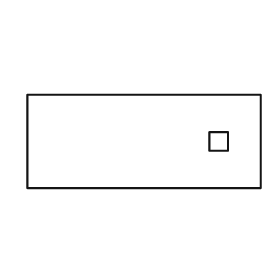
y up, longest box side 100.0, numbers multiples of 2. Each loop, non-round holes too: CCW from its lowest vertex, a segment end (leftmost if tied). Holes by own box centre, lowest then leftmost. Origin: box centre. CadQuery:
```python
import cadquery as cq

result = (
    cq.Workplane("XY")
    .moveTo(-50.0, -20.0)
    .lineTo(50.0, -20.0)
    .lineTo(50.0, 20.0)
    .lineTo(-50.0, 20.0)
    .close()
    .moveTo(28.0, -4.0)
    .lineTo(36.0, -4.0)
    .lineTo(36.0, 4.0)
    .lineTo(28.0, 4.0)
    .close()
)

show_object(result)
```